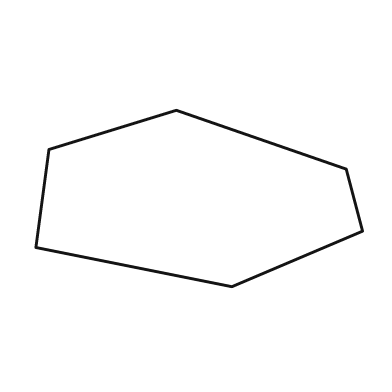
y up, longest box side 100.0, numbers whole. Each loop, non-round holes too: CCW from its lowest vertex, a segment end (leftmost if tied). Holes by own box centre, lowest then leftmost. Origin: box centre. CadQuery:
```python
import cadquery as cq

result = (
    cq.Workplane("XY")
    .moveTo(10.0, -27.0)
    .lineTo(50.0, -10.0)
    .lineTo(45.0, 9.0)
    .lineTo(-7.0, 27.0)
    .lineTo(-46.0, 15.0)
    .lineTo(-50.0, -15.0)
    .close()
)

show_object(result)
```